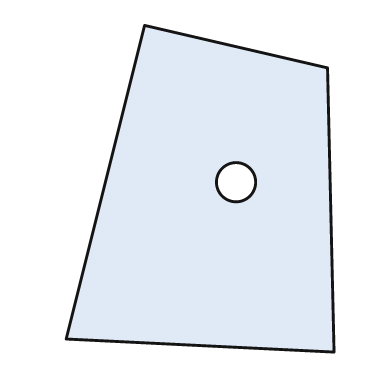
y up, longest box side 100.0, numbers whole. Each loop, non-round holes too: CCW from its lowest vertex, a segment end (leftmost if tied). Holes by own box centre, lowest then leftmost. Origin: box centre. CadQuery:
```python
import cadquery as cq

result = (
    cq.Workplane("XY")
    .moveTo(41.0, -50.0)
    .lineTo(39.0, 37.0)
    .lineTo(-17.0, 50.0)
    .lineTo(-41.0, -46.0)
    .close()
    .moveTo(11.0, 2.0)
    .circle(6.0)
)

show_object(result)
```